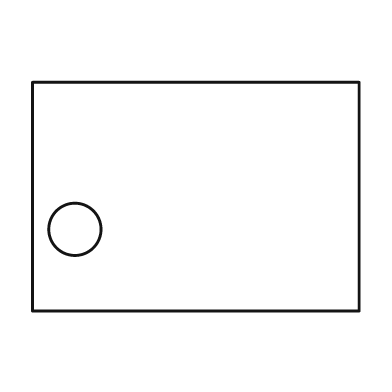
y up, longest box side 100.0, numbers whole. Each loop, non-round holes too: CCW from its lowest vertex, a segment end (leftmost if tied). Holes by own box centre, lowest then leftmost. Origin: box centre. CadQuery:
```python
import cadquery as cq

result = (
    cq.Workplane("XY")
    .moveTo(-50.0, -35.0)
    .lineTo(50.0, -35.0)
    .lineTo(50.0, 35.0)
    .lineTo(-50.0, 35.0)
    .close()
    .moveTo(-37.0, -10.0)
    .circle(8.0)
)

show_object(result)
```